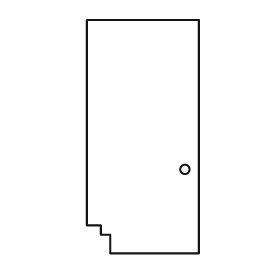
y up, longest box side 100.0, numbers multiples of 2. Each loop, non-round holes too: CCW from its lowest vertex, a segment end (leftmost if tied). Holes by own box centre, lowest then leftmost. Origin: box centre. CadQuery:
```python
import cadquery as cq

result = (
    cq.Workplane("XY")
    .moveTo(-14.0, -50.0)
    .lineTo(24.0, -50.0)
    .lineTo(24.0, 50.0)
    .lineTo(-24.0, 50.0)
    .lineTo(-24.0, -38.0)
    .lineTo(-18.0, -38.0)
    .lineTo(-18.0, -42.0)
    .lineTo(-14.0, -42.0)
    .close()
    .moveTo(18.0, -14.0)
    .circle(2.0)
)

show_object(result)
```